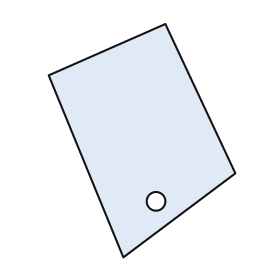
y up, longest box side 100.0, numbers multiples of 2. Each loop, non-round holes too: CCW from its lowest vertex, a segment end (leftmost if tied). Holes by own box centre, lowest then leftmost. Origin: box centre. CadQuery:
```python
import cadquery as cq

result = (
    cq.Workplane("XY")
    .moveTo(-8.0, -50.0)
    .lineTo(40.0, -14.0)
    .lineTo(10.0, 50.0)
    .lineTo(-40.0, 28.0)
    .close()
    .moveTo(6.0, -26.0)
    .circle(4.0)
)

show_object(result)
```